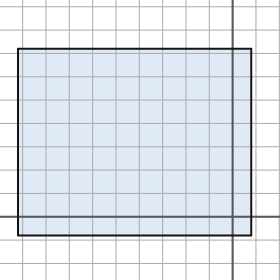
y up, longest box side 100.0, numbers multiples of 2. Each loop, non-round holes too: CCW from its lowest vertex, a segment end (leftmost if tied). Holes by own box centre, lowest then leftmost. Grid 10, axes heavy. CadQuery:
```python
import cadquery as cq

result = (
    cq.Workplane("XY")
    .moveTo(-92.0, -8.0)
    .lineTo(8.0, -8.0)
    .lineTo(8.0, 72.0)
    .lineTo(-92.0, 72.0)
    .close()
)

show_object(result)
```